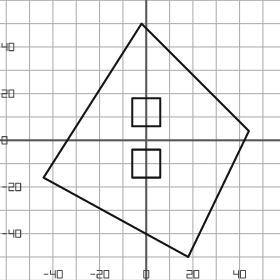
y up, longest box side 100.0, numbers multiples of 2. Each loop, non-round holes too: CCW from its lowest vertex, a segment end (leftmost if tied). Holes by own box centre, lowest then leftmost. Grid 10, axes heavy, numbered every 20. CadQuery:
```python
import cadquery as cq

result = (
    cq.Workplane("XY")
    .moveTo(18.0, -50.0)
    .lineTo(44.0, 4.0)
    .lineTo(-2.0, 50.0)
    .lineTo(-44.0, -16.0)
    .close()
    .moveTo(-6.0, -16.0)
    .lineTo(6.0, -16.0)
    .lineTo(6.0, -4.0)
    .lineTo(-6.0, -4.0)
    .close()
    .moveTo(-6.0, 6.0)
    .lineTo(6.0, 6.0)
    .lineTo(6.0, 18.0)
    .lineTo(-6.0, 18.0)
    .close()
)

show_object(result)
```